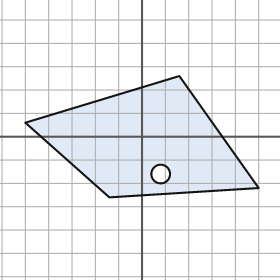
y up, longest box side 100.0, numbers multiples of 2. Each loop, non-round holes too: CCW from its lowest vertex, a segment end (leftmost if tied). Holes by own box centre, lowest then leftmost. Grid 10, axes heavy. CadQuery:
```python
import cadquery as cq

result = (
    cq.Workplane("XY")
    .moveTo(-14.0, -26.0)
    .lineTo(50.0, -22.0)
    .lineTo(16.0, 26.0)
    .lineTo(-50.0, 6.0)
    .close()
    .moveTo(8.0, -16.0)
    .circle(4.0)
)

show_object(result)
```